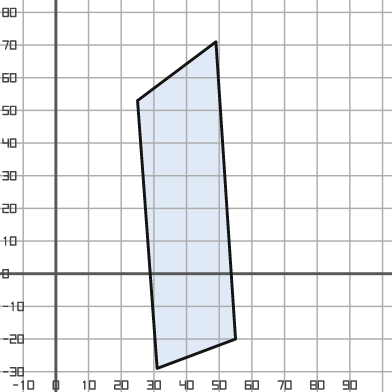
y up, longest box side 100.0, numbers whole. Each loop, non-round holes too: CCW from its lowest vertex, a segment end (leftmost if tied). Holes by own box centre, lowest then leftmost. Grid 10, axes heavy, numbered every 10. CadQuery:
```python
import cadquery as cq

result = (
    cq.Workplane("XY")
    .moveTo(31.0, -29.0)
    .lineTo(55.0, -20.0)
    .lineTo(49.0, 71.0)
    .lineTo(25.0, 53.0)
    .close()
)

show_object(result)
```